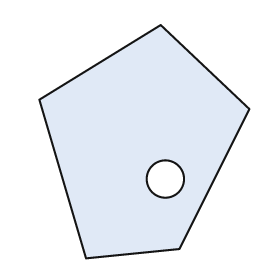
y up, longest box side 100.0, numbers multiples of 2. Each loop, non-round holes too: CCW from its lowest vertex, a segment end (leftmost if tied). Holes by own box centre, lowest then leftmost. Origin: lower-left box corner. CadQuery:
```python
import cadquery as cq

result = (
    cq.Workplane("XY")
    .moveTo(20.0, 0.0)
    .lineTo(60.0, 4.0)
    .lineTo(90.0, 64.0)
    .lineTo(52.0, 100.0)
    .lineTo(0.0, 68.0)
    .close()
    .moveTo(54.0, 34.0)
    .circle(8.0)
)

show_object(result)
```